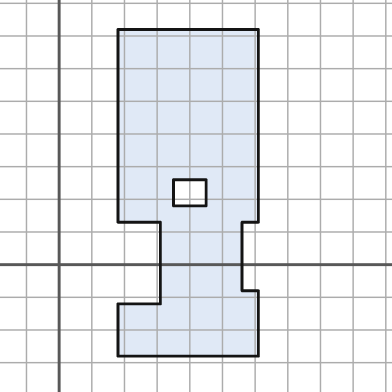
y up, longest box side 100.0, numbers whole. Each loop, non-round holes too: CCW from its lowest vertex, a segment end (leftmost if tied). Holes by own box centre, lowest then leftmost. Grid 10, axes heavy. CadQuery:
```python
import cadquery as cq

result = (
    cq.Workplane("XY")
    .moveTo(18.0, -28.0)
    .lineTo(61.0, -28.0)
    .lineTo(61.0, -8.0)
    .lineTo(56.0, -8.0)
    .lineTo(56.0, 13.0)
    .lineTo(61.0, 13.0)
    .lineTo(61.0, 72.0)
    .lineTo(18.0, 72.0)
    .lineTo(18.0, 13.0)
    .lineTo(31.0, 13.0)
    .lineTo(31.0, -12.0)
    .lineTo(18.0, -12.0)
    .close()
    .moveTo(35.0, 18.0)
    .lineTo(45.0, 18.0)
    .lineTo(45.0, 26.0)
    .lineTo(35.0, 26.0)
    .close()
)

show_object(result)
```